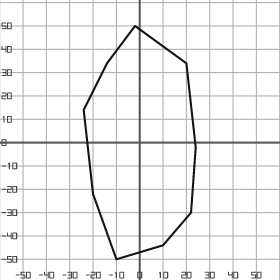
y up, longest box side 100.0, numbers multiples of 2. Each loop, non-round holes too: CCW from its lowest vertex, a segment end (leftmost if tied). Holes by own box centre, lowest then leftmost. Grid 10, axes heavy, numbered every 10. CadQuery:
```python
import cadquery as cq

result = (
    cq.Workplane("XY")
    .moveTo(-10.0, -50.0)
    .lineTo(10.0, -44.0)
    .lineTo(22.0, -30.0)
    .lineTo(24.0, -2.0)
    .lineTo(20.0, 34.0)
    .lineTo(-2.0, 50.0)
    .lineTo(-14.0, 34.0)
    .lineTo(-24.0, 14.0)
    .lineTo(-20.0, -22.0)
    .close()
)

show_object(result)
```